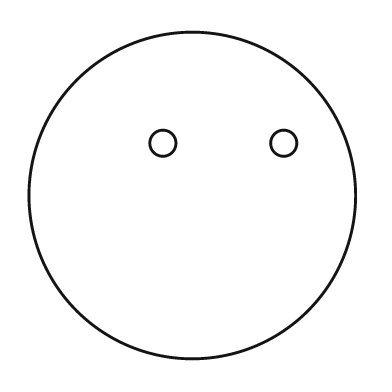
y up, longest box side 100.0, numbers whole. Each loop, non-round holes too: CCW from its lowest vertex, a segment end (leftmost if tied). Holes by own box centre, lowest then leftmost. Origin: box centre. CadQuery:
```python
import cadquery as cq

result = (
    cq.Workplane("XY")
    .moveTo(0.0, 0.0)
    .circle(50.0)
    .moveTo(-9.0, 16.0)
    .circle(4.0)
    .moveTo(28.0, 16.0)
    .circle(4.0)
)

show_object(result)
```